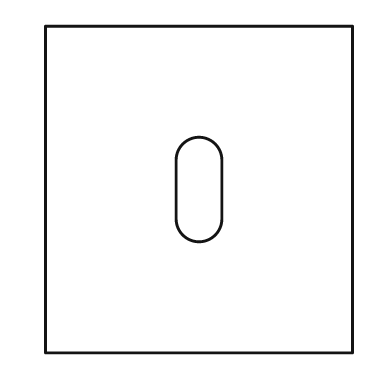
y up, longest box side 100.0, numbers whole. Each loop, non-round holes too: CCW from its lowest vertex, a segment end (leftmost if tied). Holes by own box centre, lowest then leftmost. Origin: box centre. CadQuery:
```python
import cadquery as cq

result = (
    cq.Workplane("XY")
    .moveTo(-47.0, -50.0)
    .lineTo(47.0, -50.0)
    .lineTo(47.0, 50.0)
    .lineTo(-47.0, 50.0)
    .close()
    .moveTo(-7.0, -9.0)
    .threePointArc((0.0, -16.0), (7.0, -9.0))
    .lineTo(7.0, 9.0)
    .threePointArc((0.0, 16.0), (-7.0, 9.0))
    .close()
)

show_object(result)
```